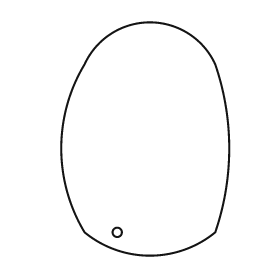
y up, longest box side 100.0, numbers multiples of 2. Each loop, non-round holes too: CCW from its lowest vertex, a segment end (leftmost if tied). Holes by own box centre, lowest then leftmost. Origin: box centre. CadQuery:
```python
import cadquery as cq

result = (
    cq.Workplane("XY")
    .moveTo(-26.0, -40.0)
    .threePointArc((2.0, -50.0), (30.0, -40.0))
    .threePointArc((36.0, -4.0), (30.0, 32.0))
    .threePointArc((2.0, 50.0), (-26.0, 32.0))
    .threePointArc((-36.0, -4.0), (-26.0, -40.0))
    .close()
    .moveTo(-12.0, -40.0)
    .circle(2.0)
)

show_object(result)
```